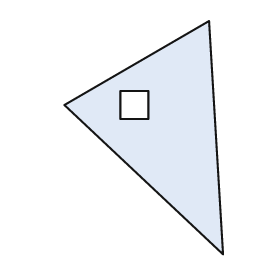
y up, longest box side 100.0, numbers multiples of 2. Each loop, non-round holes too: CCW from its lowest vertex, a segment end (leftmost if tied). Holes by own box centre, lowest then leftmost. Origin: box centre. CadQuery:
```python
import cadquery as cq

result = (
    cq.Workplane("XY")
    .moveTo(34.0, -50.0)
    .lineTo(28.0, 50.0)
    .lineTo(-34.0, 14.0)
    .close()
    .moveTo(-10.0, 8.0)
    .lineTo(2.0, 8.0)
    .lineTo(2.0, 20.0)
    .lineTo(-10.0, 20.0)
    .close()
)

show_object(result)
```